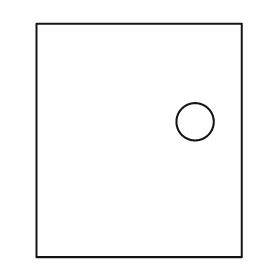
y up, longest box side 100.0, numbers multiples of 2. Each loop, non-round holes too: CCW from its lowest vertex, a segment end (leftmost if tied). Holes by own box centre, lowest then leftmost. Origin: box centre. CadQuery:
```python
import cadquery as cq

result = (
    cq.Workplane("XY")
    .moveTo(-44.0, -50.0)
    .lineTo(44.0, -50.0)
    .lineTo(44.0, 50.0)
    .lineTo(-44.0, 50.0)
    .close()
    .moveTo(24.0, 8.0)
    .circle(8.0)
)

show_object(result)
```